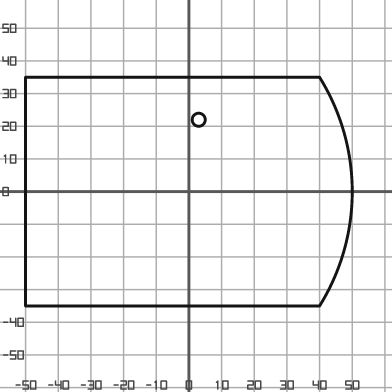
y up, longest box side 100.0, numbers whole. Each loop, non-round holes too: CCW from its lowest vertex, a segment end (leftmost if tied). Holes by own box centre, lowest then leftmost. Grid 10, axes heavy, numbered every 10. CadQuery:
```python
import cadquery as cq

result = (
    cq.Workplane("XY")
    .moveTo(-50.0, -35.0)
    .lineTo(40.0, -35.0)
    .threePointArc((50.0, 0.0), (40.0, 35.0))
    .lineTo(-50.0, 35.0)
    .close()
    .moveTo(3.0, 22.0)
    .circle(2.0)
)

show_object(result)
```